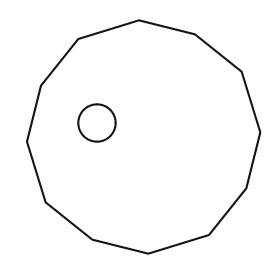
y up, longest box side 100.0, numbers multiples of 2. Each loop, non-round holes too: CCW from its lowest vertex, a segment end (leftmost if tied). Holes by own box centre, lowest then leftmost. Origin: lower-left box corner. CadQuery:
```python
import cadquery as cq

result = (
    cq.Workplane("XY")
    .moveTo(52.0, 0.0)
    .lineTo(78.0, 8.0)
    .lineTo(94.0, 28.0)
    .lineTo(100.0, 52.0)
    .lineTo(92.0, 78.0)
    .lineTo(72.0, 94.0)
    .lineTo(48.0, 100.0)
    .lineTo(22.0, 92.0)
    .lineTo(6.0, 72.0)
    .lineTo(0.0, 48.0)
    .lineTo(8.0, 22.0)
    .lineTo(28.0, 6.0)
    .close()
    .moveTo(30.0, 56.0)
    .circle(8.0)
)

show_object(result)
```